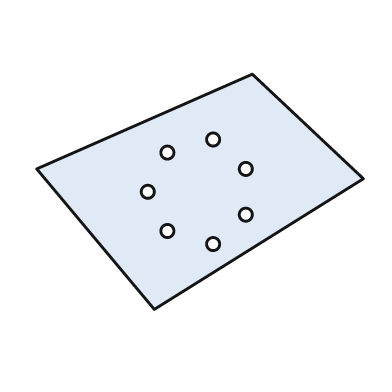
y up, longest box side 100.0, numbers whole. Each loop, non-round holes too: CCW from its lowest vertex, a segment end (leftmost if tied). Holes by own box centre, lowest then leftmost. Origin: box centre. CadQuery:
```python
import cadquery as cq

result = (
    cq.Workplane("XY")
    .moveTo(-14.0, -36.0)
    .lineTo(50.0, 4.0)
    .lineTo(16.0, 36.0)
    .lineTo(-50.0, 7.0)
    .close()
    .moveTo(4.0, -16.0)
    .circle(2.0)
    .moveTo(-10.0, -12.0)
    .circle(2.0)
    .moveTo(14.0, -7.0)
    .circle(2.0)
    .moveTo(-16.0, 0.0)
    .circle(2.0)
    .moveTo(14.0, 7.0)
    .circle(2.0)
    .moveTo(-10.0, 12.0)
    .circle(2.0)
    .moveTo(4.0, 16.0)
    .circle(2.0)
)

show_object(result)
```